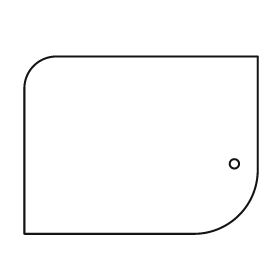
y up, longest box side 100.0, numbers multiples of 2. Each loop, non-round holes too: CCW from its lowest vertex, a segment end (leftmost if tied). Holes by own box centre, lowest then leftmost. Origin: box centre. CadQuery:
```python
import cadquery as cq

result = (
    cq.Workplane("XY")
    .moveTo(-50.0, -38.0)
    .lineTo(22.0, -38.0)
    .threePointArc((42.0, -30.0), (50.0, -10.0))
    .lineTo(50.0, 38.0)
    .lineTo(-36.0, 38.0)
    .threePointArc((-46.0, 34.0), (-50.0, 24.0))
    .close()
    .moveTo(40.0, -8.0)
    .circle(2.0)
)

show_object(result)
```